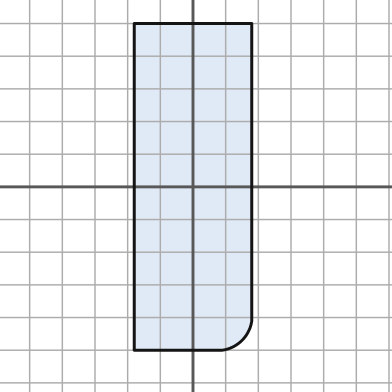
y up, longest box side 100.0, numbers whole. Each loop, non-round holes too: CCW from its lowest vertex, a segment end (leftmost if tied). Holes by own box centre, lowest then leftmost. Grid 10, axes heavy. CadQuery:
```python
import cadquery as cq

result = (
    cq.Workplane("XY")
    .moveTo(-18.0, -50.0)
    .lineTo(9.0, -50.0)
    .threePointArc((15.0, -47.0), (18.0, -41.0))
    .lineTo(18.0, 50.0)
    .lineTo(-18.0, 50.0)
    .close()
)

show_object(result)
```